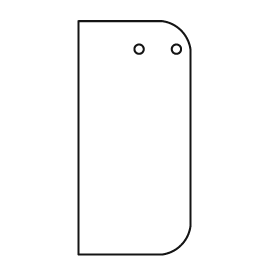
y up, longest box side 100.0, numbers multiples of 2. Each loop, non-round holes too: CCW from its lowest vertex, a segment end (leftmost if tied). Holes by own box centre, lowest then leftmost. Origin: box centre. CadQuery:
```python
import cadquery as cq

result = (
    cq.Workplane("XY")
    .moveTo(-24.0, -50.0)
    .lineTo(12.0, -50.0)
    .threePointArc((20.0, -46.0), (24.0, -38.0))
    .lineTo(24.0, 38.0)
    .threePointArc((20.0, 46.0), (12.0, 50.0))
    .lineTo(-24.0, 50.0)
    .close()
    .moveTo(2.0, 38.0)
    .circle(2.0)
    .moveTo(18.0, 38.0)
    .circle(2.0)
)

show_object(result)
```